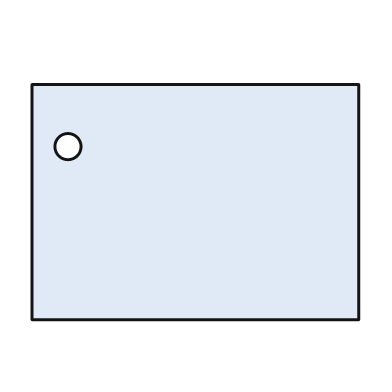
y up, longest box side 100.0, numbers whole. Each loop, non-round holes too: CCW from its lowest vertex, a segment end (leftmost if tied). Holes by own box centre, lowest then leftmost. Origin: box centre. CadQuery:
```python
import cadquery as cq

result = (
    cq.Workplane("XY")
    .moveTo(-50.0, -36.0)
    .lineTo(50.0, -36.0)
    .lineTo(50.0, 36.0)
    .lineTo(-50.0, 36.0)
    .close()
    .moveTo(-39.0, 17.0)
    .circle(4.0)
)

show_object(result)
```